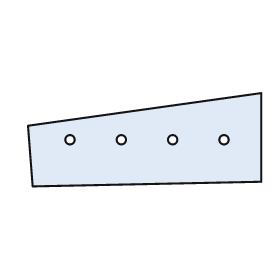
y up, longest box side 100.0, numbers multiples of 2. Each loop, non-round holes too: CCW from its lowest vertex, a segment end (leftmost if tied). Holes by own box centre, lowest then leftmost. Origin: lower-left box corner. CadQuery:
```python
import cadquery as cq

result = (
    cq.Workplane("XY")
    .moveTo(2.0, 0.0)
    .lineTo(100.0, 2.0)
    .lineTo(100.0, 40.0)
    .lineTo(0.0, 26.0)
    .close()
    .moveTo(18.0, 20.0)
    .circle(2.0)
    .moveTo(40.0, 20.0)
    .circle(2.0)
    .moveTo(62.0, 20.0)
    .circle(2.0)
    .moveTo(84.0, 20.0)
    .circle(2.0)
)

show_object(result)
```